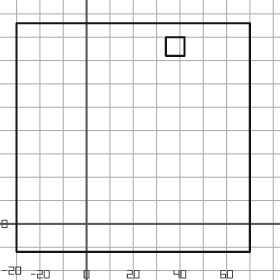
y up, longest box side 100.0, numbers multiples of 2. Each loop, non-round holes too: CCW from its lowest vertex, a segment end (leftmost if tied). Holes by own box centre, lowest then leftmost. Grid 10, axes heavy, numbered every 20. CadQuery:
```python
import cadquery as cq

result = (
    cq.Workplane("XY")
    .moveTo(-30.0, -12.0)
    .lineTo(70.0, -12.0)
    .lineTo(70.0, 86.0)
    .lineTo(-30.0, 86.0)
    .close()
    .moveTo(34.0, 72.0)
    .lineTo(42.0, 72.0)
    .lineTo(42.0, 80.0)
    .lineTo(34.0, 80.0)
    .close()
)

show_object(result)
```